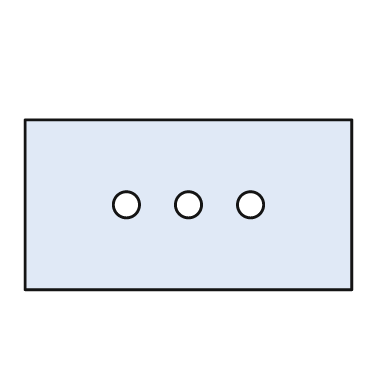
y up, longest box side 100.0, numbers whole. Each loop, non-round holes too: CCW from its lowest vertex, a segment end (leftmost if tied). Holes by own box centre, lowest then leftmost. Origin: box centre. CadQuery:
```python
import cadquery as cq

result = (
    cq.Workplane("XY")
    .moveTo(-50.0, -26.0)
    .lineTo(50.0, -26.0)
    .lineTo(50.0, 26.0)
    .lineTo(-50.0, 26.0)
    .close()
    .moveTo(-19.0, 0.0)
    .circle(4.0)
    .moveTo(0.0, 0.0)
    .circle(4.0)
    .moveTo(19.0, 0.0)
    .circle(4.0)
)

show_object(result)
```